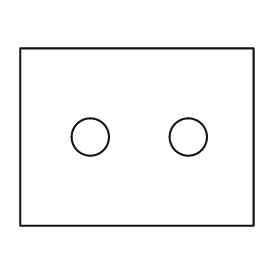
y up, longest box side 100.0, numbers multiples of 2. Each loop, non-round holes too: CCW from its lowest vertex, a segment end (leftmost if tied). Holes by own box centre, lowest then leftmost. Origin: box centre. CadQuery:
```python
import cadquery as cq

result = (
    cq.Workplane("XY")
    .moveTo(-50.0, -38.0)
    .lineTo(50.0, -38.0)
    .lineTo(50.0, 38.0)
    .lineTo(-50.0, 38.0)
    .close()
    .moveTo(-20.0, 0.0)
    .circle(8.0)
    .moveTo(22.0, 0.0)
    .circle(8.0)
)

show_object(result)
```